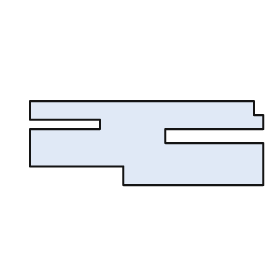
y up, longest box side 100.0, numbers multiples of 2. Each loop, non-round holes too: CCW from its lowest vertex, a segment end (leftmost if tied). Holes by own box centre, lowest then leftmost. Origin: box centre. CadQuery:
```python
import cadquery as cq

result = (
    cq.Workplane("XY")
    .moveTo(-10.0, -18.0)
    .lineTo(50.0, -18.0)
    .lineTo(50.0, 0.0)
    .lineTo(8.0, 0.0)
    .lineTo(8.0, 6.0)
    .lineTo(50.0, 6.0)
    .lineTo(50.0, 12.0)
    .lineTo(46.0, 12.0)
    .lineTo(46.0, 18.0)
    .lineTo(-50.0, 18.0)
    .lineTo(-50.0, 10.0)
    .lineTo(-20.0, 10.0)
    .lineTo(-20.0, 6.0)
    .lineTo(-50.0, 6.0)
    .lineTo(-50.0, -10.0)
    .lineTo(-10.0, -10.0)
    .close()
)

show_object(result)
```